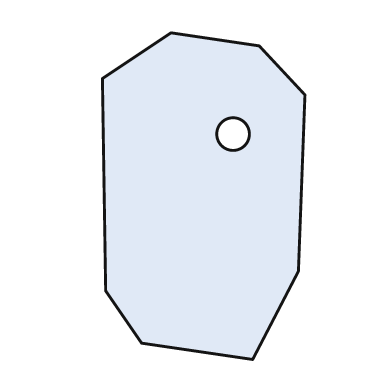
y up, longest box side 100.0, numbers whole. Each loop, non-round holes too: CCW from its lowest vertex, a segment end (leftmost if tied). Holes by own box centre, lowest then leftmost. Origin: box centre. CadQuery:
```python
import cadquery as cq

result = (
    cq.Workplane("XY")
    .moveTo(15.0, -50.0)
    .lineTo(29.0, -23.0)
    .lineTo(31.0, 31.0)
    .lineTo(17.0, 46.0)
    .lineTo(-10.0, 50.0)
    .lineTo(-31.0, 36.0)
    .lineTo(-30.0, -29.0)
    .lineTo(-19.0, -45.0)
    .close()
    .moveTo(9.0, 19.0)
    .circle(5.0)
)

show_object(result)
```